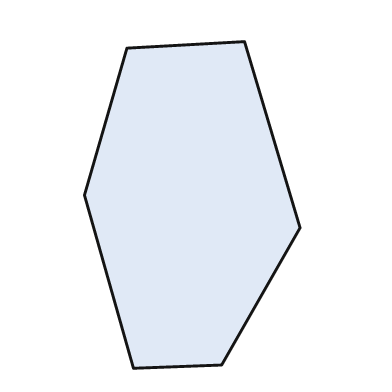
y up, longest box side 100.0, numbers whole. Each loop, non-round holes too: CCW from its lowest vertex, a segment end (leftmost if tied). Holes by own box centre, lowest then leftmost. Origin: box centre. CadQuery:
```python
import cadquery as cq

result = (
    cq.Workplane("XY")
    .moveTo(-18.0, -50.0)
    .lineTo(9.0, -49.0)
    .lineTo(33.0, -7.0)
    .lineTo(16.0, 50.0)
    .lineTo(-20.0, 48.0)
    .lineTo(-33.0, 3.0)
    .close()
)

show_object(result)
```